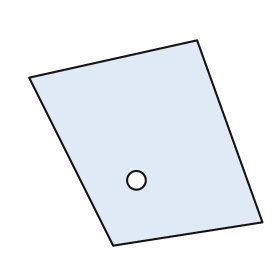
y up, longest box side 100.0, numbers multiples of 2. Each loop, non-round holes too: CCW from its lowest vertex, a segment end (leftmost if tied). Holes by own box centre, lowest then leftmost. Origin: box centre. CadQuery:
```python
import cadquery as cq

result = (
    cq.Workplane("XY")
    .moveTo(-14.0, -44.0)
    .lineTo(50.0, -34.0)
    .lineTo(22.0, 44.0)
    .lineTo(-50.0, 28.0)
    .close()
    .moveTo(-4.0, -16.0)
    .circle(4.0)
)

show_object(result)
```